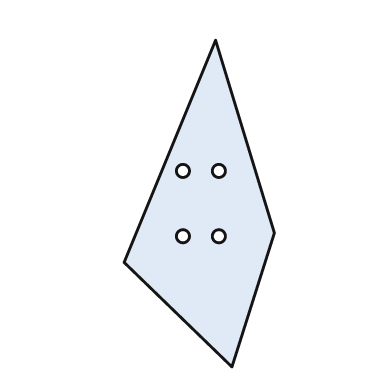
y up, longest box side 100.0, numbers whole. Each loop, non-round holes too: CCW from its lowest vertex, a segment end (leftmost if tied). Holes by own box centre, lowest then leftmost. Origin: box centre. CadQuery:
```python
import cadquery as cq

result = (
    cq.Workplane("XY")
    .moveTo(10.0, -50.0)
    .lineTo(23.0, -9.0)
    .lineTo(5.0, 50.0)
    .lineTo(-23.0, -18.0)
    .close()
    .moveTo(-5.0, -10.0)
    .circle(2.0)
    .moveTo(6.0, -10.0)
    .circle(2.0)
    .moveTo(-5.0, 10.0)
    .circle(2.0)
    .moveTo(6.0, 10.0)
    .circle(2.0)
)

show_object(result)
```